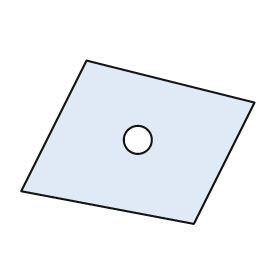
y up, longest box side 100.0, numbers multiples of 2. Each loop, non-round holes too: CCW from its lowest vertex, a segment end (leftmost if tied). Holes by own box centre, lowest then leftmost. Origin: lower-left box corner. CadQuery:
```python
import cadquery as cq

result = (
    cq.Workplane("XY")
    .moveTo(74.0, 0.0)
    .lineTo(100.0, 52.0)
    .lineTo(28.0, 70.0)
    .lineTo(0.0, 14.0)
    .close()
    .moveTo(50.0, 36.0)
    .circle(6.0)
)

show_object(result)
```